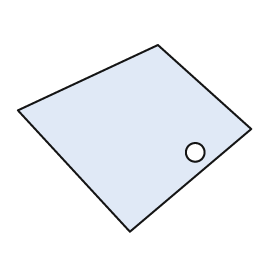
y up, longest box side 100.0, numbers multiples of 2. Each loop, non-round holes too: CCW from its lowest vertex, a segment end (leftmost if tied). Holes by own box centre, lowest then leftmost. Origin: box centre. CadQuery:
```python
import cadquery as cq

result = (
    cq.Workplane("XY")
    .moveTo(-2.0, -40.0)
    .lineTo(50.0, 4.0)
    .lineTo(10.0, 40.0)
    .lineTo(-50.0, 12.0)
    .close()
    .moveTo(26.0, -6.0)
    .circle(4.0)
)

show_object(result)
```